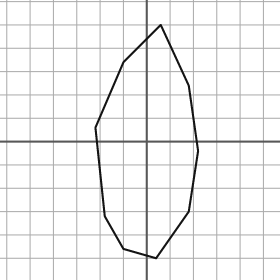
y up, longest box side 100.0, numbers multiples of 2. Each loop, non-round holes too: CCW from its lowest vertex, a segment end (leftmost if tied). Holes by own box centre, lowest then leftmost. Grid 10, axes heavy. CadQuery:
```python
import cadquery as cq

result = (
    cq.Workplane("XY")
    .moveTo(4.0, -50.0)
    .lineTo(18.0, -30.0)
    .lineTo(22.0, -4.0)
    .lineTo(18.0, 24.0)
    .lineTo(6.0, 50.0)
    .lineTo(-10.0, 34.0)
    .lineTo(-22.0, 6.0)
    .lineTo(-18.0, -32.0)
    .lineTo(-10.0, -46.0)
    .close()
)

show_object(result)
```